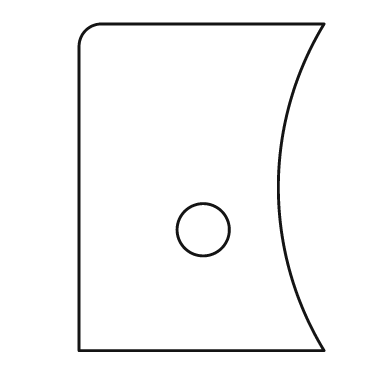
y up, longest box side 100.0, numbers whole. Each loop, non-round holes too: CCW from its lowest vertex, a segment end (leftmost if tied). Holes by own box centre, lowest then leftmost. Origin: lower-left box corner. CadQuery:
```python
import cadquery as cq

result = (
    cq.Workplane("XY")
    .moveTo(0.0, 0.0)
    .lineTo(75.0, 0.0)
    .threePointArc((61.0, 50.0), (75.0, 100.0))
    .lineTo(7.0, 100.0)
    .threePointArc((2.0, 98.0), (0.0, 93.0))
    .close()
    .moveTo(38.0, 37.0)
    .circle(8.0)
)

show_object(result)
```